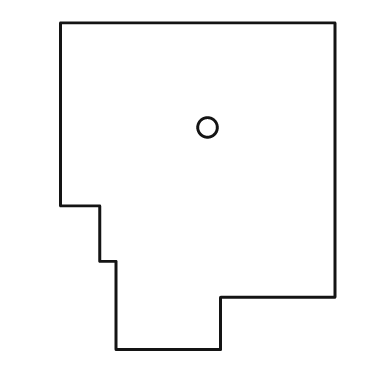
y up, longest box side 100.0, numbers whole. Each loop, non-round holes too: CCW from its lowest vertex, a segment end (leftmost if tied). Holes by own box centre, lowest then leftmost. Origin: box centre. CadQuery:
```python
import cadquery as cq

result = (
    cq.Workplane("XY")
    .moveTo(-25.0, -50.0)
    .lineTo(7.0, -50.0)
    .lineTo(7.0, -34.0)
    .lineTo(42.0, -34.0)
    .lineTo(42.0, 50.0)
    .lineTo(-42.0, 50.0)
    .lineTo(-42.0, -6.0)
    .lineTo(-30.0, -6.0)
    .lineTo(-30.0, -23.0)
    .lineTo(-25.0, -23.0)
    .close()
    .moveTo(3.0, 18.0)
    .circle(3.0)
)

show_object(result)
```